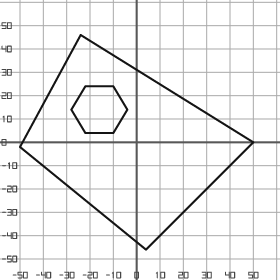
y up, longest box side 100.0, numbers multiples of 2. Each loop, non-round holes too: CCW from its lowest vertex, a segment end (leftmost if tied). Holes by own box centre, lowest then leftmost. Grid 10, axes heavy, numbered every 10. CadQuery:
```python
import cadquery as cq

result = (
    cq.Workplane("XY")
    .moveTo(4.0, -46.0)
    .lineTo(50.0, 0.0)
    .lineTo(-24.0, 46.0)
    .lineTo(-50.0, -2.0)
    .close()
    .moveTo(-22.0, 4.0)
    .lineTo(-10.0, 4.0)
    .lineTo(-4.0, 14.0)
    .lineTo(-10.0, 24.0)
    .lineTo(-22.0, 24.0)
    .lineTo(-28.0, 14.0)
    .close()
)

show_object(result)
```